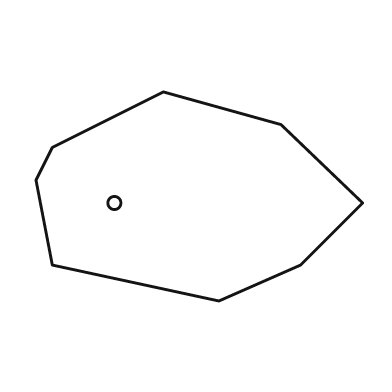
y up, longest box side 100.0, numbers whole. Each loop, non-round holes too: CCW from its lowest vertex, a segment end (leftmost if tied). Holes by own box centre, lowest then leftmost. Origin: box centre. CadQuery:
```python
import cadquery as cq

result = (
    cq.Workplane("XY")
    .moveTo(6.0, -32.0)
    .lineTo(31.0, -21.0)
    .lineTo(50.0, -2.0)
    .lineTo(25.0, 22.0)
    .lineTo(-11.0, 32.0)
    .lineTo(-45.0, 15.0)
    .lineTo(-50.0, 5.0)
    .lineTo(-45.0, -21.0)
    .close()
    .moveTo(-26.0, -2.0)
    .circle(2.0)
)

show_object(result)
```